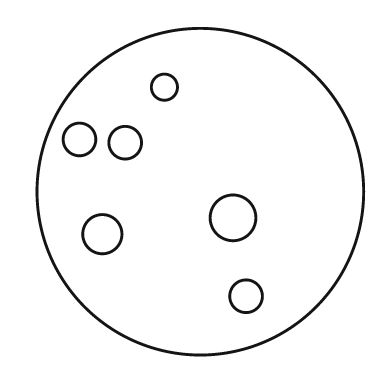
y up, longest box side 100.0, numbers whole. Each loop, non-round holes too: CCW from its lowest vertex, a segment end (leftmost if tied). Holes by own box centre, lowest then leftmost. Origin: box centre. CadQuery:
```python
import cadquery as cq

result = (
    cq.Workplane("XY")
    .moveTo(0.0, 0.0)
    .circle(50.0)
    .moveTo(14.0, -32.0)
    .circle(5.0)
    .moveTo(-30.0, -13.0)
    .circle(6.0)
    .moveTo(10.0, -8.0)
    .circle(7.0)
    .moveTo(-23.0, 15.0)
    .circle(5.0)
    .moveTo(-37.0, 16.0)
    .circle(5.0)
    .moveTo(-11.0, 32.0)
    .circle(4.0)
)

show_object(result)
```